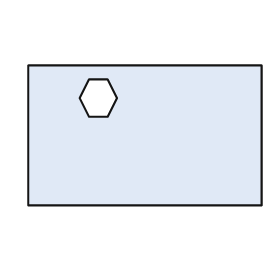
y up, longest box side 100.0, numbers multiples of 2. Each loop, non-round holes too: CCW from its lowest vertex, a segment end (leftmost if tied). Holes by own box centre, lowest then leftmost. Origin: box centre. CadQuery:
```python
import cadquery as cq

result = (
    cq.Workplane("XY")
    .moveTo(-50.0, -30.0)
    .lineTo(50.0, -30.0)
    .lineTo(50.0, 30.0)
    .lineTo(-50.0, 30.0)
    .close()
    .moveTo(-24.0, 8.0)
    .lineTo(-16.0, 8.0)
    .lineTo(-12.0, 16.0)
    .lineTo(-16.0, 24.0)
    .lineTo(-24.0, 24.0)
    .lineTo(-28.0, 16.0)
    .close()
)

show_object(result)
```